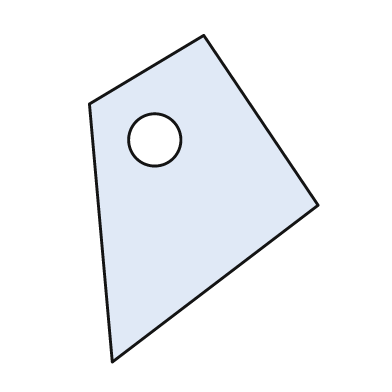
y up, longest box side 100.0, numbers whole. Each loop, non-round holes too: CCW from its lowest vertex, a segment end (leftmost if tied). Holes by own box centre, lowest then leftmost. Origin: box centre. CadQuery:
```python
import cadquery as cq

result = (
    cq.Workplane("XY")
    .moveTo(-28.0, -50.0)
    .lineTo(35.0, -2.0)
    .lineTo(0.0, 50.0)
    .lineTo(-35.0, 29.0)
    .close()
    .moveTo(-15.0, 18.0)
    .circle(8.0)
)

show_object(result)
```